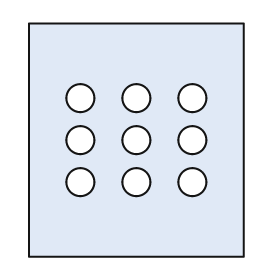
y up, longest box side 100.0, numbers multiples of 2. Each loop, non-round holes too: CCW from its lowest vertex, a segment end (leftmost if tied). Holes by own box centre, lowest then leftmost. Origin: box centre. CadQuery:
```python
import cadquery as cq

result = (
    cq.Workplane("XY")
    .moveTo(-46.0, -50.0)
    .lineTo(46.0, -50.0)
    .lineTo(46.0, 50.0)
    .lineTo(-46.0, 50.0)
    .close()
    .moveTo(-24.0, -18.0)
    .circle(6.0)
    .moveTo(0.0, -18.0)
    .circle(6.0)
    .moveTo(24.0, -18.0)
    .circle(6.0)
    .moveTo(-24.0, 0.0)
    .circle(6.0)
    .moveTo(0.0, 0.0)
    .circle(6.0)
    .moveTo(24.0, 0.0)
    .circle(6.0)
    .moveTo(-24.0, 18.0)
    .circle(6.0)
    .moveTo(0.0, 18.0)
    .circle(6.0)
    .moveTo(24.0, 18.0)
    .circle(6.0)
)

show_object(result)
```